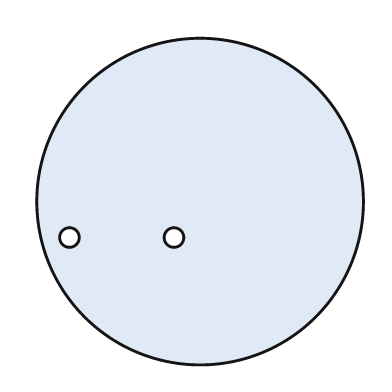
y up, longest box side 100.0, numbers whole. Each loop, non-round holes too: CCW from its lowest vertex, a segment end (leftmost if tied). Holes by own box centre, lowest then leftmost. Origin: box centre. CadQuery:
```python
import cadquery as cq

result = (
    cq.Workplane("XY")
    .moveTo(0.0, 0.0)
    .circle(50.0)
    .moveTo(-40.0, -11.0)
    .circle(3.0)
    .moveTo(-8.0, -11.0)
    .circle(3.0)
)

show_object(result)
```